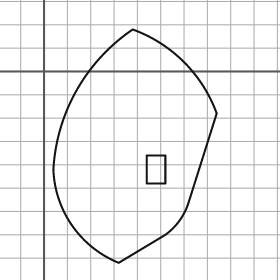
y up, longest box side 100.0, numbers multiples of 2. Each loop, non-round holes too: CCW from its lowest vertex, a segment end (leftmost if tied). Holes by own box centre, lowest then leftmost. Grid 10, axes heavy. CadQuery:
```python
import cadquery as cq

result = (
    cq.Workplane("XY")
    .moveTo(32.0, -82.0)
    .lineTo(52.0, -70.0)
    .threePointArc((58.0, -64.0), (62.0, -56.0))
    .lineTo(74.0, -18.0)
    .threePointArc((60.0, 4.0), (38.0, 18.0))
    .threePointArc((14.0, -8.0), (4.0, -42.0))
    .threePointArc((12.0, -66.0), (32.0, -82.0))
    .close()
    .moveTo(44.0, -48.0)
    .lineTo(52.0, -48.0)
    .lineTo(52.0, -36.0)
    .lineTo(44.0, -36.0)
    .close()
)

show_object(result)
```